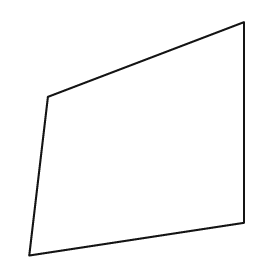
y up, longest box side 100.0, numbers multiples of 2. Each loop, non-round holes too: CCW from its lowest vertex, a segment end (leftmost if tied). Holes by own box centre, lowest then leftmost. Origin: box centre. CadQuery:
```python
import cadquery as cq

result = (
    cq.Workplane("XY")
    .moveTo(-46.0, -50.0)
    .lineTo(46.0, -36.0)
    .lineTo(46.0, 50.0)
    .lineTo(-38.0, 18.0)
    .close()
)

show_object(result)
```